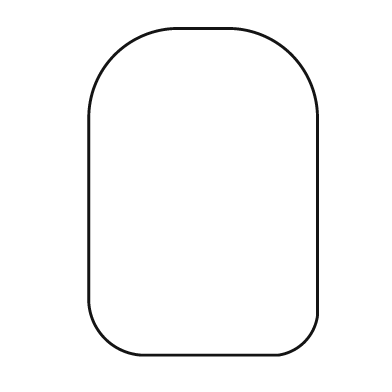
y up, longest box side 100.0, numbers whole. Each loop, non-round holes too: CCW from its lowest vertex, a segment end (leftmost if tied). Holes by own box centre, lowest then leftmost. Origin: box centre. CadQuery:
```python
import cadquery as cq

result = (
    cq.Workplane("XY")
    .moveTo(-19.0, -50.0)
    .lineTo(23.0, -50.0)
    .threePointArc((31.0, -46.0), (35.0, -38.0))
    .lineTo(35.0, 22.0)
    .threePointArc((27.0, 42.0), (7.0, 50.0))
    .lineTo(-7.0, 50.0)
    .threePointArc((-27.0, 42.0), (-35.0, 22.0))
    .lineTo(-35.0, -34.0)
    .threePointArc((-30.0, -45.0), (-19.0, -50.0))
    .close()
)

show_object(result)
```